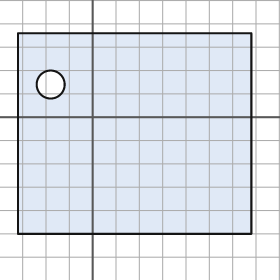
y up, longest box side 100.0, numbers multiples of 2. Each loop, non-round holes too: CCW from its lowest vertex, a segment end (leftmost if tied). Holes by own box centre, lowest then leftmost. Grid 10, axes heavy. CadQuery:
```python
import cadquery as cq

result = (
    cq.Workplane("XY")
    .moveTo(-32.0, -50.0)
    .lineTo(68.0, -50.0)
    .lineTo(68.0, 36.0)
    .lineTo(-32.0, 36.0)
    .close()
    .moveTo(-18.0, 14.0)
    .circle(6.0)
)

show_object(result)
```